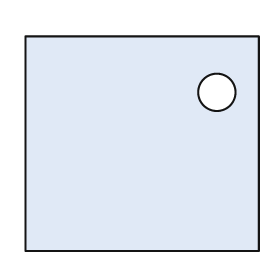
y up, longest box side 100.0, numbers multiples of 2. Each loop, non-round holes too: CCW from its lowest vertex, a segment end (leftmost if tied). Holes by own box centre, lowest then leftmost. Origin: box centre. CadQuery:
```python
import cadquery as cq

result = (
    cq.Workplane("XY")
    .moveTo(-50.0, -46.0)
    .lineTo(50.0, -46.0)
    .lineTo(50.0, 46.0)
    .lineTo(-50.0, 46.0)
    .close()
    .moveTo(32.0, 22.0)
    .circle(8.0)
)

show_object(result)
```